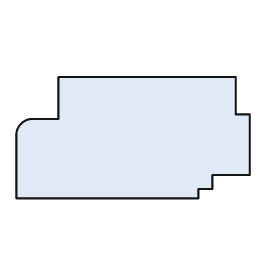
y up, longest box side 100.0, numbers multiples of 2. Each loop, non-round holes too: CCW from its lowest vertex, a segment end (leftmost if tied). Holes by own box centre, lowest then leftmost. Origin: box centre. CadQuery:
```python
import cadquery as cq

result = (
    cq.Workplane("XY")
    .moveTo(-50.0, -26.0)
    .lineTo(28.0, -26.0)
    .lineTo(28.0, -22.0)
    .lineTo(34.0, -22.0)
    .lineTo(34.0, -16.0)
    .lineTo(50.0, -16.0)
    .lineTo(50.0, 10.0)
    .lineTo(44.0, 10.0)
    .lineTo(44.0, 26.0)
    .lineTo(-32.0, 26.0)
    .lineTo(-32.0, 8.0)
    .lineTo(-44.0, 8.0)
    .threePointArc((-48.0, 6.0), (-50.0, 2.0))
    .close()
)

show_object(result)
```